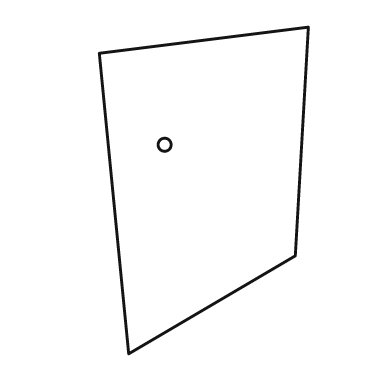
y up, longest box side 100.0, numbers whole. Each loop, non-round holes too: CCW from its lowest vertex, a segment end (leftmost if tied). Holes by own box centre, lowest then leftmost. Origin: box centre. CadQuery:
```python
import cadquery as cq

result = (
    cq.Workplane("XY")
    .moveTo(-23.0, -50.0)
    .lineTo(28.0, -20.0)
    .lineTo(32.0, 50.0)
    .lineTo(-32.0, 42.0)
    .close()
    .moveTo(-12.0, 14.0)
    .circle(2.0)
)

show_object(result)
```